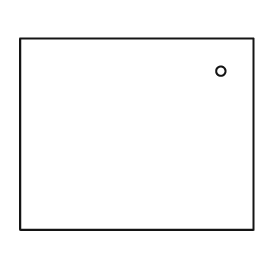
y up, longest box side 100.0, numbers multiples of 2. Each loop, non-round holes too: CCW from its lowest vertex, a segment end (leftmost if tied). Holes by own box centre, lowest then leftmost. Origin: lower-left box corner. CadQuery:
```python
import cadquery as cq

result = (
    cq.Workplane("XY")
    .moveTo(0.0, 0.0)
    .lineTo(100.0, 0.0)
    .lineTo(100.0, 82.0)
    .lineTo(0.0, 82.0)
    .close()
    .moveTo(86.0, 68.0)
    .circle(2.0)
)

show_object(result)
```